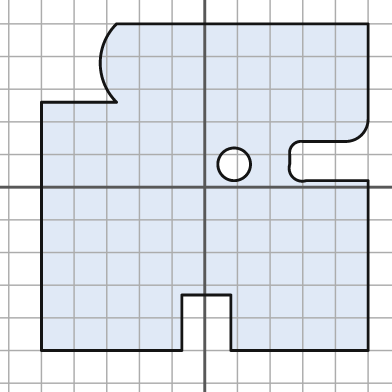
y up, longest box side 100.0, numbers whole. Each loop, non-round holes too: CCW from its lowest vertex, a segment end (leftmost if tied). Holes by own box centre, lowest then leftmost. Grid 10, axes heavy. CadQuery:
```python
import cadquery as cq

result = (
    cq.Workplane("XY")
    .moveTo(-50.0, -50.0)
    .lineTo(-7.0, -50.0)
    .lineTo(-7.0, -33.0)
    .lineTo(8.0, -33.0)
    .lineTo(8.0, -50.0)
    .lineTo(50.0, -50.0)
    .lineTo(50.0, 2.0)
    .lineTo(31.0, 2.0)
    .threePointArc((27.0, 3.0), (26.0, 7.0))
    .lineTo(26.0, 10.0)
    .threePointArc((27.0, 13.0), (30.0, 14.0))
    .lineTo(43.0, 14.0)
    .threePointArc((48.0, 16.0), (50.0, 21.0))
    .lineTo(50.0, 50.0)
    .lineTo(-27.0, 50.0)
    .threePointArc((-32.0, 38.0), (-27.0, 26.0))
    .lineTo(-50.0, 26.0)
    .close()
    .moveTo(9.0, 7.0)
    .circle(5.0)
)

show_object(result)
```